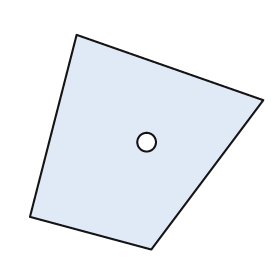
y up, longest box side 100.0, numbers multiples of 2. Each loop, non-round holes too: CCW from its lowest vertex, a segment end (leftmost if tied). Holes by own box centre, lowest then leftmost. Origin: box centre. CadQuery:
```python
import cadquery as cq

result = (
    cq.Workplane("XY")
    .moveTo(2.0, -46.0)
    .lineTo(50.0, 18.0)
    .lineTo(-30.0, 46.0)
    .lineTo(-50.0, -32.0)
    .close()
    .moveTo(0.0, 0.0)
    .circle(4.0)
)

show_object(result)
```